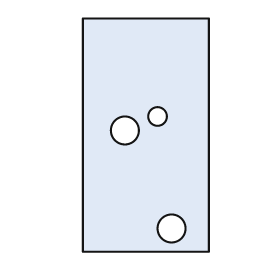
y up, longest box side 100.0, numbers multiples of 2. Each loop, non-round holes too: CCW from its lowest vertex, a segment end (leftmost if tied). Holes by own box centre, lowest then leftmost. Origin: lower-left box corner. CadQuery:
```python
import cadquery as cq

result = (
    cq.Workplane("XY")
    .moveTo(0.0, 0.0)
    .lineTo(54.0, 0.0)
    .lineTo(54.0, 100.0)
    .lineTo(0.0, 100.0)
    .close()
    .moveTo(38.0, 10.0)
    .circle(6.0)
    .moveTo(18.0, 52.0)
    .circle(6.0)
    .moveTo(32.0, 58.0)
    .circle(4.0)
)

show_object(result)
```